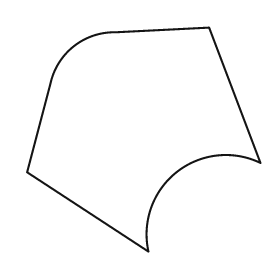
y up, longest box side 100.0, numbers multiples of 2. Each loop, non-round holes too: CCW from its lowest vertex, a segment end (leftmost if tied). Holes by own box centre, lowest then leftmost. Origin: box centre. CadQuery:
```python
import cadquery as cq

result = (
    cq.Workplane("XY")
    .moveTo(2.0, -48.0)
    .threePointArc((14.0, -14.0), (50.0, -10.0))
    .lineTo(28.0, 48.0)
    .lineTo(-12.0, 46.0)
    .threePointArc((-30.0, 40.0), (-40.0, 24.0))
    .lineTo(-50.0, -14.0)
    .close()
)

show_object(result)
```